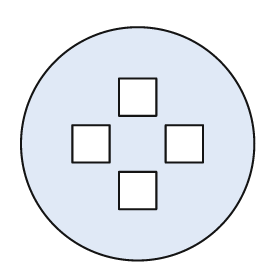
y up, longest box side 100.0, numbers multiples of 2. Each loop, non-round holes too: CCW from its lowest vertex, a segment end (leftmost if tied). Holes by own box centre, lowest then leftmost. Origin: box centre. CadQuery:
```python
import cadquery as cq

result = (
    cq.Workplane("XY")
    .moveTo(0.0, 0.0)
    .circle(50.0)
    .moveTo(-8.0, -28.0)
    .lineTo(8.0, -28.0)
    .lineTo(8.0, -12.0)
    .lineTo(-8.0, -12.0)
    .close()
    .moveTo(-28.0, -8.0)
    .lineTo(-12.0, -8.0)
    .lineTo(-12.0, 8.0)
    .lineTo(-28.0, 8.0)
    .close()
    .moveTo(12.0, -8.0)
    .lineTo(28.0, -8.0)
    .lineTo(28.0, 8.0)
    .lineTo(12.0, 8.0)
    .close()
    .moveTo(-8.0, 12.0)
    .lineTo(8.0, 12.0)
    .lineTo(8.0, 28.0)
    .lineTo(-8.0, 28.0)
    .close()
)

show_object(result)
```